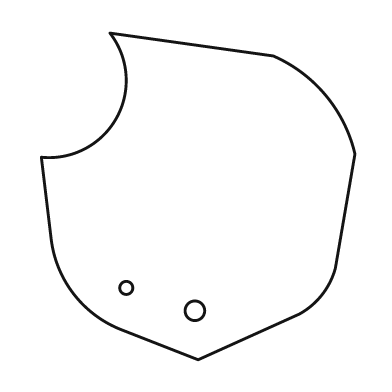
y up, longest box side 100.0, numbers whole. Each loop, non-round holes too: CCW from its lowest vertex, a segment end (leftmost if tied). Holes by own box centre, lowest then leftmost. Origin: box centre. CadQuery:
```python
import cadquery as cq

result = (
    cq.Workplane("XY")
    .moveTo(0.0, -50.0)
    .lineTo(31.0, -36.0)
    .threePointArc((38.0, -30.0), (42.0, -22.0))
    .lineTo(48.0, 13.0)
    .threePointArc((39.0, 31.0), (23.0, 43.0))
    .lineTo(-27.0, 50.0)
    .threePointArc((-25.0, 24.0), (-48.0, 12.0))
    .lineTo(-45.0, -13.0)
    .threePointArc((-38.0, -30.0), (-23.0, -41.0))
    .close()
    .moveTo(-1.0, -35.0)
    .circle(3.0)
    .moveTo(-22.0, -28.0)
    .circle(2.0)
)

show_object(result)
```